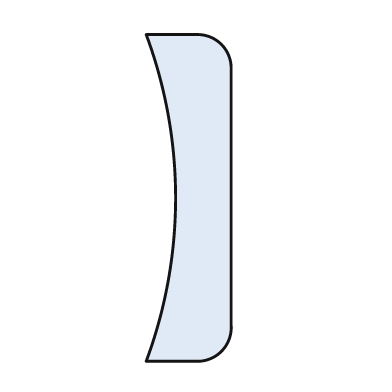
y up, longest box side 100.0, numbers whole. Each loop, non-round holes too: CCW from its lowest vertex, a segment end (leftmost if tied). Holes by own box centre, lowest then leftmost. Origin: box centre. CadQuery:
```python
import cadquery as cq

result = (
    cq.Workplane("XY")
    .moveTo(-13.0, -50.0)
    .lineTo(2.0, -50.0)
    .threePointArc((10.0, -47.0), (13.0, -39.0))
    .lineTo(13.0, 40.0)
    .threePointArc((10.0, 47.0), (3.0, 50.0))
    .lineTo(-13.0, 50.0)
    .threePointArc((-4.0, 0.0), (-13.0, -50.0))
    .close()
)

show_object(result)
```